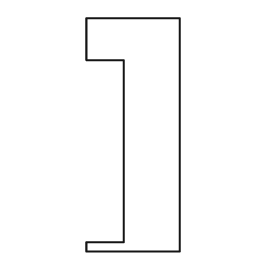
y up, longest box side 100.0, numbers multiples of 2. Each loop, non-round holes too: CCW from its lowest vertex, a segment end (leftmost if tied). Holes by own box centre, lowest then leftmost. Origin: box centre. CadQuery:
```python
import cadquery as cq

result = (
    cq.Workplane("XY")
    .moveTo(-20.0, -50.0)
    .lineTo(20.0, -50.0)
    .lineTo(20.0, 50.0)
    .lineTo(-20.0, 50.0)
    .lineTo(-20.0, 32.0)
    .lineTo(-4.0, 32.0)
    .lineTo(-4.0, -46.0)
    .lineTo(-20.0, -46.0)
    .close()
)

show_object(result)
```